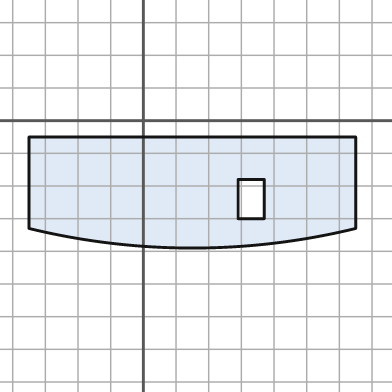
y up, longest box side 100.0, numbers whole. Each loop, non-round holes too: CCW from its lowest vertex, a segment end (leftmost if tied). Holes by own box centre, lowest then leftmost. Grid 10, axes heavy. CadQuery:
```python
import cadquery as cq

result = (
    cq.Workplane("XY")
    .moveTo(-35.0, -33.0)
    .threePointArc((15.0, -39.0), (65.0, -33.0))
    .lineTo(65.0, -5.0)
    .lineTo(-35.0, -5.0)
    .close()
    .moveTo(29.0, -30.0)
    .lineTo(37.0, -30.0)
    .lineTo(37.0, -18.0)
    .lineTo(29.0, -18.0)
    .close()
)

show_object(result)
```